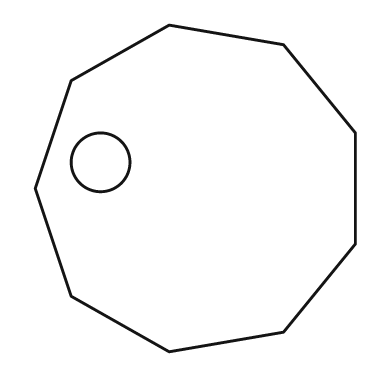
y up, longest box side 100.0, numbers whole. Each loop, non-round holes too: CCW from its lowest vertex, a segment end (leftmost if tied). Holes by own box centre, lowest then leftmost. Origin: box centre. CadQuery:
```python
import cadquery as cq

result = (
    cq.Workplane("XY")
    .moveTo(-8.0, -50.0)
    .lineTo(27.0, -44.0)
    .lineTo(49.0, -17.0)
    .lineTo(49.0, 17.0)
    .lineTo(27.0, 44.0)
    .lineTo(-8.0, 50.0)
    .lineTo(-38.0, 33.0)
    .lineTo(-49.0, 0.0)
    .lineTo(-38.0, -33.0)
    .close()
    .moveTo(-29.0, 8.0)
    .circle(9.0)
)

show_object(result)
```